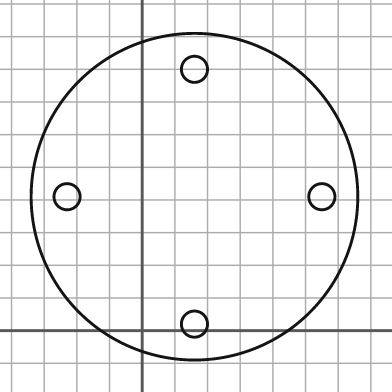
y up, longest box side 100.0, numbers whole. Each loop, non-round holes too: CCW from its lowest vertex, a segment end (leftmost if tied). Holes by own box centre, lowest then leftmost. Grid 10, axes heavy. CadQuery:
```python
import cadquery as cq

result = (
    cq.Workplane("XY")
    .moveTo(16.0, 41.0)
    .circle(50.0)
    .moveTo(16.0, 2.0)
    .circle(4.0)
    .moveTo(-23.0, 41.0)
    .circle(4.0)
    .moveTo(55.0, 41.0)
    .circle(4.0)
    .moveTo(16.0, 80.0)
    .circle(4.0)
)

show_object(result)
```